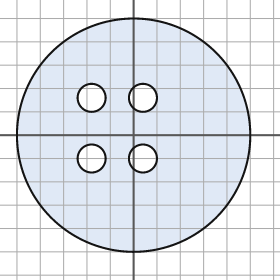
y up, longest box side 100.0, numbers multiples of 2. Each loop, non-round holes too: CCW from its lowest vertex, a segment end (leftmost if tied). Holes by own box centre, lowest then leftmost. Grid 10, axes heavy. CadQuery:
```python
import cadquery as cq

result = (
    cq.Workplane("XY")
    .moveTo(0.0, 0.0)
    .circle(50.0)
    .moveTo(-18.0, -10.0)
    .circle(6.0)
    .moveTo(4.0, -10.0)
    .circle(6.0)
    .moveTo(-18.0, 16.0)
    .circle(6.0)
    .moveTo(4.0, 16.0)
    .circle(6.0)
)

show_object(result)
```